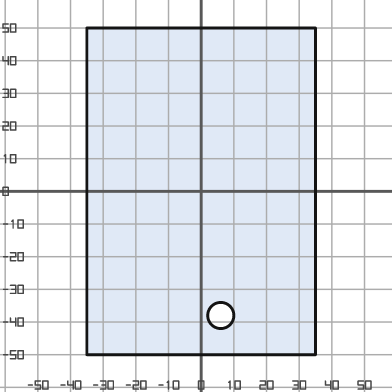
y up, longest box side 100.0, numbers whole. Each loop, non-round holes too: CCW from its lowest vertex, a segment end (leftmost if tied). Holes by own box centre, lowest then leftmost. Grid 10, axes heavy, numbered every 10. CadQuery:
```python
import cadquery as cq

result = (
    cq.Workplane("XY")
    .moveTo(-35.0, -50.0)
    .lineTo(35.0, -50.0)
    .lineTo(35.0, 50.0)
    .lineTo(-35.0, 50.0)
    .close()
    .moveTo(6.0, -38.0)
    .circle(4.0)
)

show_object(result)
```